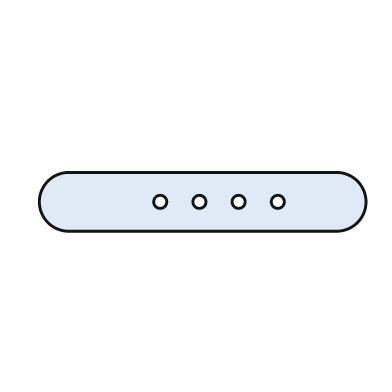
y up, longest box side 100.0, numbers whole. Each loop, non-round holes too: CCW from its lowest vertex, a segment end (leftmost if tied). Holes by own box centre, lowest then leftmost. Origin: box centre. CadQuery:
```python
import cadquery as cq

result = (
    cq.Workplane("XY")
    .moveTo(-41.0, -9.0)
    .lineTo(41.0, -9.0)
    .threePointArc((50.0, 0.0), (41.0, 9.0))
    .lineTo(-41.0, 9.0)
    .threePointArc((-50.0, 0.0), (-41.0, -9.0))
    .close()
    .moveTo(-13.0, 0.0)
    .circle(2.0)
    .moveTo(-1.0, 0.0)
    .circle(2.0)
    .moveTo(11.0, 0.0)
    .circle(2.0)
    .moveTo(23.0, 0.0)
    .circle(2.0)
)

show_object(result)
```